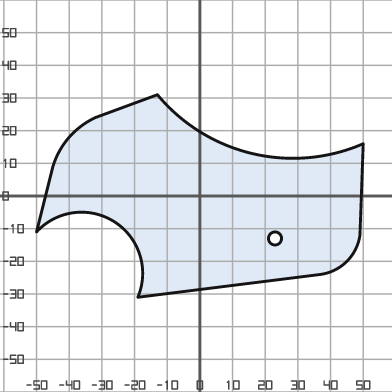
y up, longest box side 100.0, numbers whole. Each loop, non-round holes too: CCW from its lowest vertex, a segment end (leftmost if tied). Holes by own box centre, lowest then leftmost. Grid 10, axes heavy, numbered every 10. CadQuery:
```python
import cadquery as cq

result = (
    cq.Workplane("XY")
    .moveTo(-19.0, -31.0)
    .lineTo(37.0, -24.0)
    .threePointArc((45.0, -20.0), (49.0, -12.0))
    .lineTo(50.0, 16.0)
    .threePointArc((16.0, 13.0), (-13.0, 31.0))
    .lineTo(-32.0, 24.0)
    .threePointArc((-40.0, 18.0), (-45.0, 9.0))
    .lineTo(-50.0, -11.0)
    .threePointArc((-26.0, -8.0), (-19.0, -31.0))
    .close()
    .moveTo(23.0, -13.0)
    .circle(2.0)
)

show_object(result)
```